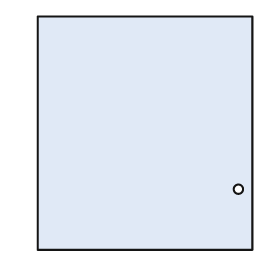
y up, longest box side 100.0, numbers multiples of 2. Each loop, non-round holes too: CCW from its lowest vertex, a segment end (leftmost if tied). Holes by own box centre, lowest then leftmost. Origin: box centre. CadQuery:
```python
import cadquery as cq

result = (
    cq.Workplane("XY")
    .moveTo(-46.0, -50.0)
    .lineTo(46.0, -50.0)
    .lineTo(46.0, 50.0)
    .lineTo(-46.0, 50.0)
    .close()
    .moveTo(40.0, -24.0)
    .circle(2.0)
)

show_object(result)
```